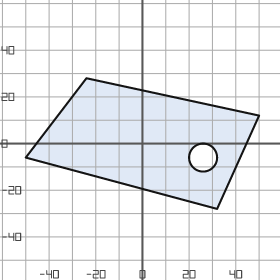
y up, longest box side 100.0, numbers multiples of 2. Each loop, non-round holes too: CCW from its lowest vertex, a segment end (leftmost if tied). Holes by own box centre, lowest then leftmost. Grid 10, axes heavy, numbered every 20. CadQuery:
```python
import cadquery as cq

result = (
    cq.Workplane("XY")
    .moveTo(32.0, -28.0)
    .lineTo(50.0, 12.0)
    .lineTo(-24.0, 28.0)
    .lineTo(-50.0, -6.0)
    .close()
    .moveTo(26.0, -6.0)
    .circle(6.0)
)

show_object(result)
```